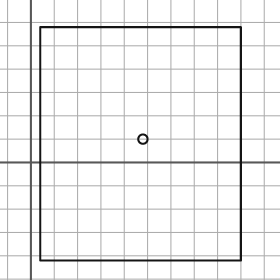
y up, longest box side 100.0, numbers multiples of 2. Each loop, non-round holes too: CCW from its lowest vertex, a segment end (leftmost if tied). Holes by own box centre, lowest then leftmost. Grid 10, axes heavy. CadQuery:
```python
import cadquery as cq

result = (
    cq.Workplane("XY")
    .moveTo(4.0, -42.0)
    .lineTo(90.0, -42.0)
    .lineTo(90.0, 58.0)
    .lineTo(4.0, 58.0)
    .close()
    .moveTo(48.0, 10.0)
    .circle(2.0)
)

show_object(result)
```